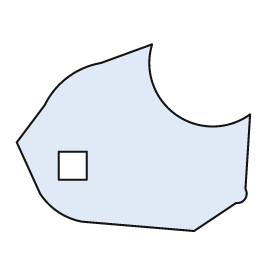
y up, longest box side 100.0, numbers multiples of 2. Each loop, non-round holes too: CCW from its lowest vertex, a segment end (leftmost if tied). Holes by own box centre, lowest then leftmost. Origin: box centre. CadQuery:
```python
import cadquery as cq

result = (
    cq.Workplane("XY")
    .moveTo(26.0, -40.0)
    .lineTo(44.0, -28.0)
    .threePointArc((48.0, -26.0), (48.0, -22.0))
    .lineTo(50.0, 10.0)
    .threePointArc((18.0, 10.0), (8.0, 40.0))
    .lineTo(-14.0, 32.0)
    .threePointArc((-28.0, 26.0), (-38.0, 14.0))
    .lineTo(-50.0, -2.0)
    .lineTo(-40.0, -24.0)
    .threePointArc((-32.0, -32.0), (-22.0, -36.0))
    .close()
    .moveTo(-32.0, -18.0)
    .lineTo(-20.0, -18.0)
    .lineTo(-20.0, -6.0)
    .lineTo(-32.0, -6.0)
    .close()
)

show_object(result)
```